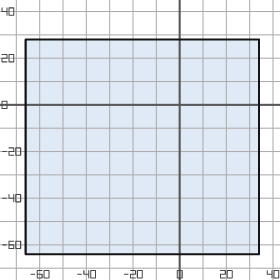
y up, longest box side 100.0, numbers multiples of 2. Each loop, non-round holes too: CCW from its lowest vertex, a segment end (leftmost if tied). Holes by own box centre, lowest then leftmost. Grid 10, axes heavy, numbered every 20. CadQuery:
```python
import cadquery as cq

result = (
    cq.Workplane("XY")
    .moveTo(-66.0, -64.0)
    .lineTo(34.0, -64.0)
    .lineTo(34.0, 28.0)
    .lineTo(-66.0, 28.0)
    .close()
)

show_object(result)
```